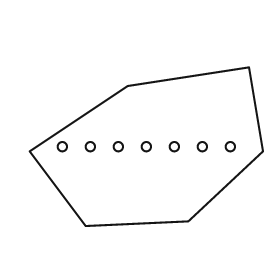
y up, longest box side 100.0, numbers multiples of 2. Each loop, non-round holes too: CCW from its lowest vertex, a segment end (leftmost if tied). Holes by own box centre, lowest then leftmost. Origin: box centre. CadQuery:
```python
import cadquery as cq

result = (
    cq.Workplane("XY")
    .moveTo(-26.0, -34.0)
    .lineTo(18.0, -32.0)
    .lineTo(50.0, -2.0)
    .lineTo(44.0, 34.0)
    .lineTo(-8.0, 26.0)
    .lineTo(-50.0, -2.0)
    .close()
    .moveTo(-36.0, 0.0)
    .circle(2.0)
    .moveTo(-24.0, 0.0)
    .circle(2.0)
    .moveTo(-12.0, 0.0)
    .circle(2.0)
    .moveTo(0.0, 0.0)
    .circle(2.0)
    .moveTo(12.0, 0.0)
    .circle(2.0)
    .moveTo(24.0, 0.0)
    .circle(2.0)
    .moveTo(36.0, 0.0)
    .circle(2.0)
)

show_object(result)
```